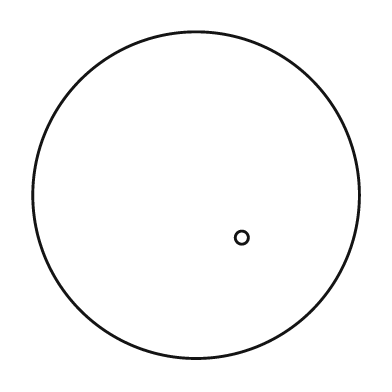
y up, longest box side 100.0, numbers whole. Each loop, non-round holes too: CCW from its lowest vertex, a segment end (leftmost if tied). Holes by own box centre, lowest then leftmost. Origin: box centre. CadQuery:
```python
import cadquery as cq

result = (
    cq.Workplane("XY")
    .moveTo(0.0, 0.0)
    .circle(50.0)
    .moveTo(14.0, -13.0)
    .circle(2.0)
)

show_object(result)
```